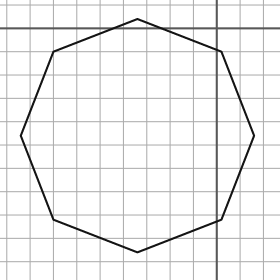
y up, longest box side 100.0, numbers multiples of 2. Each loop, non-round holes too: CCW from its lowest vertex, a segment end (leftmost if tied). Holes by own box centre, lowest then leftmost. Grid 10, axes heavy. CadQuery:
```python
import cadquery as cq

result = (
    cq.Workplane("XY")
    .moveTo(-34.0, -96.0)
    .lineTo(2.0, -82.0)
    .lineTo(16.0, -46.0)
    .lineTo(2.0, -10.0)
    .lineTo(-34.0, 4.0)
    .lineTo(-70.0, -10.0)
    .lineTo(-84.0, -46.0)
    .lineTo(-70.0, -82.0)
    .close()
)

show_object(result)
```